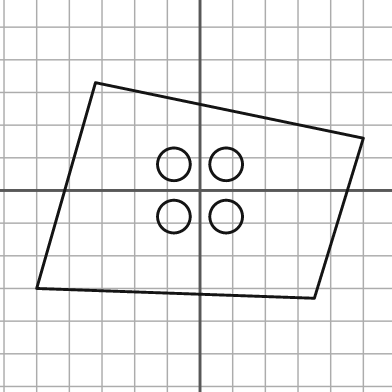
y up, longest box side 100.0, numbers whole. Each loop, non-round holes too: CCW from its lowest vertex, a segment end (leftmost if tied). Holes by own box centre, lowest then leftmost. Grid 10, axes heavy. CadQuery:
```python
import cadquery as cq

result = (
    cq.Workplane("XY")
    .moveTo(35.0, -33.0)
    .lineTo(50.0, 16.0)
    .lineTo(-32.0, 33.0)
    .lineTo(-50.0, -30.0)
    .close()
    .moveTo(-8.0, -8.0)
    .circle(5.0)
    .moveTo(8.0, -8.0)
    .circle(5.0)
    .moveTo(-8.0, 8.0)
    .circle(5.0)
    .moveTo(8.0, 8.0)
    .circle(5.0)
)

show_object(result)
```